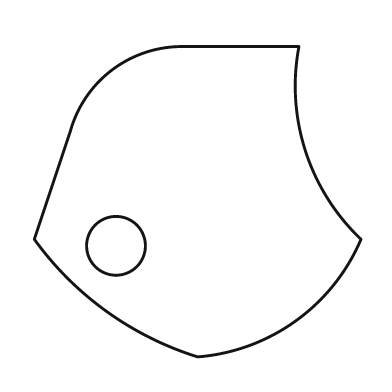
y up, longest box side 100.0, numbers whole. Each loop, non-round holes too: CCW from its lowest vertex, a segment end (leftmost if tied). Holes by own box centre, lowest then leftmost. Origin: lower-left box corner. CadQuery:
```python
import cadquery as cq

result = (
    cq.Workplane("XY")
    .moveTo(50.0, 0.0)
    .threePointArc((80.0, 11.0), (100.0, 36.0))
    .threePointArc((83.0, 63.0), (81.0, 95.0))
    .lineTo(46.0, 95.0)
    .threePointArc((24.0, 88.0), (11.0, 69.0))
    .lineTo(0.0, 36.0)
    .threePointArc((22.0, 14.0), (50.0, 0.0))
    .close()
    .moveTo(25.0, 34.0)
    .circle(9.0)
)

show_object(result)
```